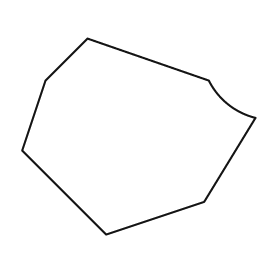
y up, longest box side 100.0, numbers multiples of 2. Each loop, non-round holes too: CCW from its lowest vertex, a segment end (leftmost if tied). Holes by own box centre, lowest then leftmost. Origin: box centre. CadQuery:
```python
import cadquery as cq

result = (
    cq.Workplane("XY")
    .moveTo(-14.0, -42.0)
    .lineTo(28.0, -28.0)
    .lineTo(50.0, 8.0)
    .threePointArc((38.0, 14.0), (30.0, 24.0))
    .lineTo(-22.0, 42.0)
    .lineTo(-40.0, 24.0)
    .lineTo(-50.0, -6.0)
    .close()
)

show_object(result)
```